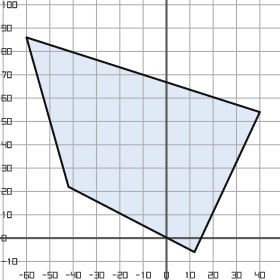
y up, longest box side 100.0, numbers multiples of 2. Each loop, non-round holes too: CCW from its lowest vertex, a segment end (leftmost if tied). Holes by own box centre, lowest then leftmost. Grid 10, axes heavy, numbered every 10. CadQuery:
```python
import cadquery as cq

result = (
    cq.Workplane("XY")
    .moveTo(12.0, -6.0)
    .lineTo(40.0, 54.0)
    .lineTo(-60.0, 86.0)
    .lineTo(-42.0, 22.0)
    .close()
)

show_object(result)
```